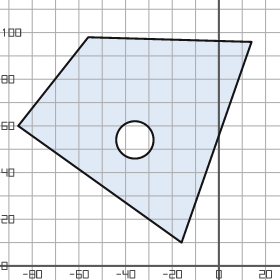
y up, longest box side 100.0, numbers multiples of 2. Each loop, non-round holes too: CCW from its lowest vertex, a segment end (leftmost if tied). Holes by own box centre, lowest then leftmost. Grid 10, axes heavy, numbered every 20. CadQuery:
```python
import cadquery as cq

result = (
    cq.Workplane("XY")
    .moveTo(-16.0, 10.0)
    .lineTo(14.0, 96.0)
    .lineTo(-56.0, 98.0)
    .lineTo(-86.0, 60.0)
    .close()
    .moveTo(-36.0, 54.0)
    .circle(8.0)
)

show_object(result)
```